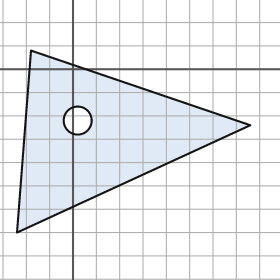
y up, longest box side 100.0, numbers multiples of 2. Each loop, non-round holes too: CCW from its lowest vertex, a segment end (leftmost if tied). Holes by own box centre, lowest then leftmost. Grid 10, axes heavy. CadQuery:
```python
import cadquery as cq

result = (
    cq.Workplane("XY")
    .moveTo(-24.0, -70.0)
    .lineTo(76.0, -24.0)
    .lineTo(-18.0, 8.0)
    .close()
    .moveTo(2.0, -22.0)
    .circle(6.0)
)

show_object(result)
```